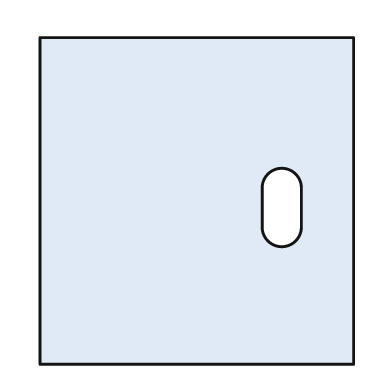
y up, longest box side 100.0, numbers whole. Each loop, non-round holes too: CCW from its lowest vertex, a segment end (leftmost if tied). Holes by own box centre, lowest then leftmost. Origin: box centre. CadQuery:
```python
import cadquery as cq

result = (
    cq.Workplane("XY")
    .moveTo(-48.0, -50.0)
    .lineTo(48.0, -50.0)
    .lineTo(48.0, 50.0)
    .lineTo(-48.0, 50.0)
    .close()
    .moveTo(20.0, -8.0)
    .threePointArc((26.0, -14.0), (32.0, -8.0))
    .lineTo(32.0, 4.0)
    .threePointArc((26.0, 10.0), (20.0, 4.0))
    .close()
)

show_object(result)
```